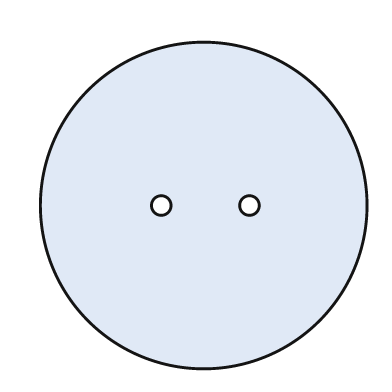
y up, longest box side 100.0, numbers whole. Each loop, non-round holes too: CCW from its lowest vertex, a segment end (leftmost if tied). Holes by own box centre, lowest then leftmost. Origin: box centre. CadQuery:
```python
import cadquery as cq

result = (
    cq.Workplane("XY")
    .moveTo(0.0, 0.0)
    .circle(50.0)
    .moveTo(-13.0, 0.0)
    .circle(3.0)
    .moveTo(14.0, 0.0)
    .circle(3.0)
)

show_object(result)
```